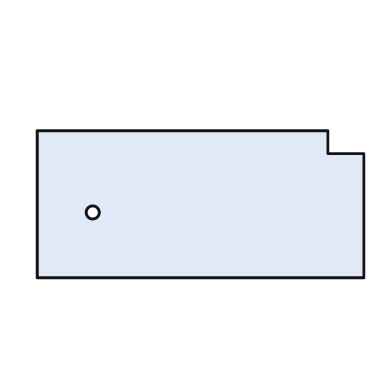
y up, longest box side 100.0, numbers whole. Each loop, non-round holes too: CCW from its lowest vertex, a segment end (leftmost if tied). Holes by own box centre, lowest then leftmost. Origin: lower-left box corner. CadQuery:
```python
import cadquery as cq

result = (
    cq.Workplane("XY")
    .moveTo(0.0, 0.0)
    .lineTo(100.0, 0.0)
    .lineTo(100.0, 38.0)
    .lineTo(89.0, 38.0)
    .lineTo(89.0, 45.0)
    .lineTo(0.0, 45.0)
    .close()
    .moveTo(17.0, 20.0)
    .circle(2.0)
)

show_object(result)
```